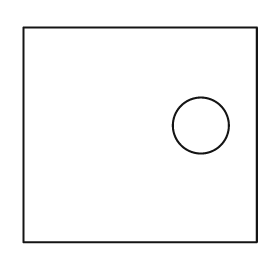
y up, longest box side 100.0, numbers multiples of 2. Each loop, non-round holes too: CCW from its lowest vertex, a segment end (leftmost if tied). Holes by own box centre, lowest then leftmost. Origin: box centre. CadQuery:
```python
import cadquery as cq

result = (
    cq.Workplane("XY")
    .moveTo(-50.0, -46.0)
    .lineTo(50.0, -46.0)
    .lineTo(50.0, 46.0)
    .lineTo(-50.0, 46.0)
    .close()
    .moveTo(26.0, 4.0)
    .circle(12.0)
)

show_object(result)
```